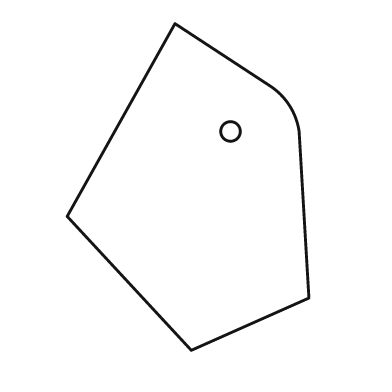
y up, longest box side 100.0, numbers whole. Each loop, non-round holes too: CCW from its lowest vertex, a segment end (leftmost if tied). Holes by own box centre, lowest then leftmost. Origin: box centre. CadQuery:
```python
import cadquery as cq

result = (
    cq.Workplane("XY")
    .moveTo(1.0, -50.0)
    .lineTo(37.0, -34.0)
    .lineTo(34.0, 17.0)
    .threePointArc((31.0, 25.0), (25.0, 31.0))
    .lineTo(-4.0, 50.0)
    .lineTo(-37.0, -9.0)
    .close()
    .moveTo(13.0, 17.0)
    .circle(3.0)
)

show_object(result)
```